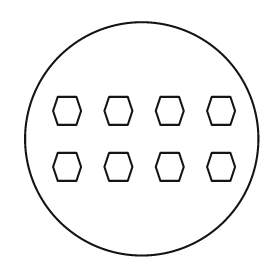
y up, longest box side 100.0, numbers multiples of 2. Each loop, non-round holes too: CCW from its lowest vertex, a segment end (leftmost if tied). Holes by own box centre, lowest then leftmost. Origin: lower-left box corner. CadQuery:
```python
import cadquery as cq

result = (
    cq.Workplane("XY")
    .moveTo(50.0, 50.0)
    .circle(50.0)
    .moveTo(14.0, 32.0)
    .lineTo(22.0, 32.0)
    .lineTo(24.0, 38.0)
    .lineTo(22.0, 44.0)
    .lineTo(14.0, 44.0)
    .lineTo(12.0, 38.0)
    .close()
    .moveTo(36.0, 32.0)
    .lineTo(44.0, 32.0)
    .lineTo(46.0, 38.0)
    .lineTo(44.0, 44.0)
    .lineTo(36.0, 44.0)
    .lineTo(34.0, 38.0)
    .close()
    .moveTo(58.0, 32.0)
    .lineTo(66.0, 32.0)
    .lineTo(68.0, 38.0)
    .lineTo(66.0, 44.0)
    .lineTo(58.0, 44.0)
    .lineTo(56.0, 38.0)
    .close()
    .moveTo(80.0, 32.0)
    .lineTo(88.0, 32.0)
    .lineTo(90.0, 38.0)
    .lineTo(88.0, 44.0)
    .lineTo(80.0, 44.0)
    .lineTo(78.0, 38.0)
    .close()
    .moveTo(14.0, 56.0)
    .lineTo(22.0, 56.0)
    .lineTo(24.0, 62.0)
    .lineTo(22.0, 68.0)
    .lineTo(14.0, 68.0)
    .lineTo(12.0, 62.0)
    .close()
    .moveTo(36.0, 56.0)
    .lineTo(44.0, 56.0)
    .lineTo(46.0, 62.0)
    .lineTo(44.0, 68.0)
    .lineTo(36.0, 68.0)
    .lineTo(34.0, 62.0)
    .close()
    .moveTo(58.0, 56.0)
    .lineTo(66.0, 56.0)
    .lineTo(68.0, 62.0)
    .lineTo(66.0, 68.0)
    .lineTo(58.0, 68.0)
    .lineTo(56.0, 62.0)
    .close()
    .moveTo(80.0, 56.0)
    .lineTo(88.0, 56.0)
    .lineTo(90.0, 62.0)
    .lineTo(88.0, 68.0)
    .lineTo(80.0, 68.0)
    .lineTo(78.0, 62.0)
    .close()
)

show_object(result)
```